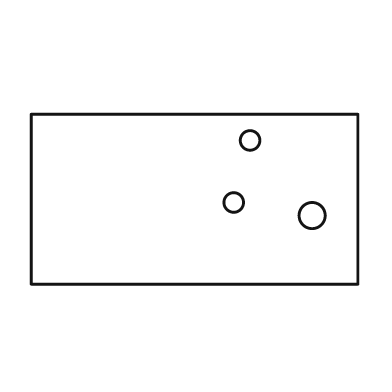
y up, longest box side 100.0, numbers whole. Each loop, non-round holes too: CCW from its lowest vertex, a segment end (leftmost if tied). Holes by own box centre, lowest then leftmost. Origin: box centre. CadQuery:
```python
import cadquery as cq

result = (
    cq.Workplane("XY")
    .moveTo(-50.0, -26.0)
    .lineTo(50.0, -26.0)
    .lineTo(50.0, 26.0)
    .lineTo(-50.0, 26.0)
    .close()
    .moveTo(36.0, -5.0)
    .circle(4.0)
    .moveTo(12.0, -1.0)
    .circle(3.0)
    .moveTo(17.0, 18.0)
    .circle(3.0)
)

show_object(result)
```